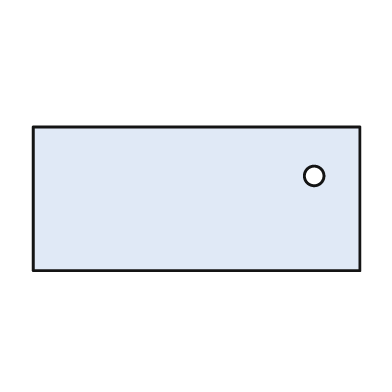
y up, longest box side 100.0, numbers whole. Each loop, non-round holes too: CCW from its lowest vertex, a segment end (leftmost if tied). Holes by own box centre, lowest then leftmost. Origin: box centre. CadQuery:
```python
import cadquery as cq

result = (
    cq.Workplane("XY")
    .moveTo(-50.0, -22.0)
    .lineTo(50.0, -22.0)
    .lineTo(50.0, 22.0)
    .lineTo(-50.0, 22.0)
    .close()
    .moveTo(36.0, 7.0)
    .circle(3.0)
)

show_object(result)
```